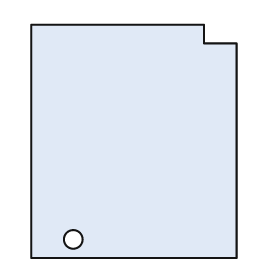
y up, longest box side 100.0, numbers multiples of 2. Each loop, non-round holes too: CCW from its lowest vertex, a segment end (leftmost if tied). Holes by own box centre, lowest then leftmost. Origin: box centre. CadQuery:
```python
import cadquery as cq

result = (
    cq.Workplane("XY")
    .moveTo(-44.0, -50.0)
    .lineTo(44.0, -50.0)
    .lineTo(44.0, 42.0)
    .lineTo(30.0, 42.0)
    .lineTo(30.0, 50.0)
    .lineTo(-44.0, 50.0)
    .close()
    .moveTo(-26.0, -42.0)
    .circle(4.0)
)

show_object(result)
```